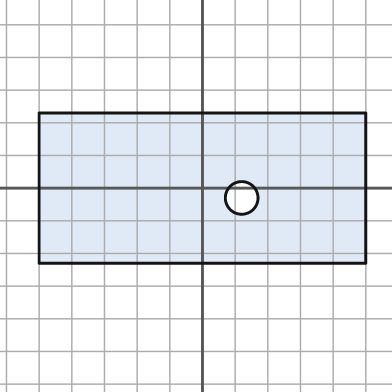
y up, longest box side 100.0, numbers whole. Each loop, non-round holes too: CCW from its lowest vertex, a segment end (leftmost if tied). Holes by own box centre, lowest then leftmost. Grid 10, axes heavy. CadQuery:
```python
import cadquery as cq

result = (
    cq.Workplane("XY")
    .moveTo(-50.0, -23.0)
    .lineTo(50.0, -23.0)
    .lineTo(50.0, 23.0)
    .lineTo(-50.0, 23.0)
    .close()
    .moveTo(12.0, -3.0)
    .circle(5.0)
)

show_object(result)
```